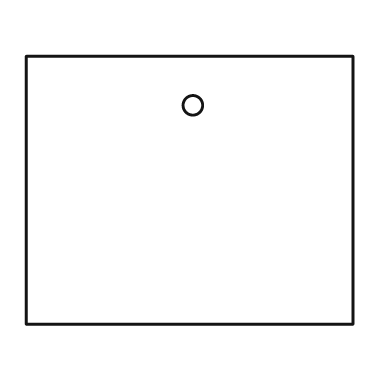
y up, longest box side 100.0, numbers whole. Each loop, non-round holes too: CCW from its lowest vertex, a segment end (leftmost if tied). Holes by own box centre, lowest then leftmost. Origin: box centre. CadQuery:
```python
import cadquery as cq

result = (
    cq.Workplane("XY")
    .moveTo(-50.0, -41.0)
    .lineTo(50.0, -41.0)
    .lineTo(50.0, 41.0)
    .lineTo(-50.0, 41.0)
    .close()
    .moveTo(1.0, 26.0)
    .circle(3.0)
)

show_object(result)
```